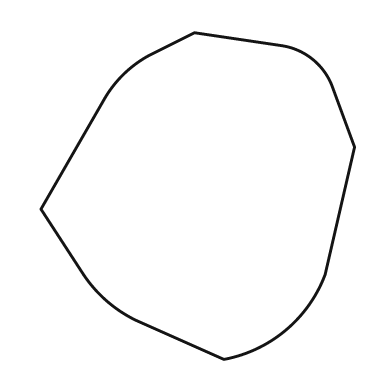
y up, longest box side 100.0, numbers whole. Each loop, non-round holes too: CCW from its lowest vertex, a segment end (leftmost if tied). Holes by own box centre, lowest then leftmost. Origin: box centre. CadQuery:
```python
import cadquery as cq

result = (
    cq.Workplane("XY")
    .moveTo(8.0, -50.0)
    .threePointArc((27.0, -41.0), (39.0, -24.0))
    .lineTo(48.0, 15.0)
    .lineTo(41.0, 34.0)
    .threePointArc((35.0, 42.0), (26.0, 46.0))
    .lineTo(-1.0, 50.0)
    .lineTo(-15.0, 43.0)
    .threePointArc((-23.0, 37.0), (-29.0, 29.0))
    .lineTo(-48.0, -4.0)
    .lineTo(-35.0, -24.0)
    .threePointArc((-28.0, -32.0), (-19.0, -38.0))
    .close()
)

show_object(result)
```